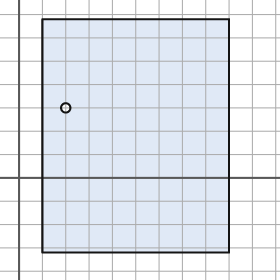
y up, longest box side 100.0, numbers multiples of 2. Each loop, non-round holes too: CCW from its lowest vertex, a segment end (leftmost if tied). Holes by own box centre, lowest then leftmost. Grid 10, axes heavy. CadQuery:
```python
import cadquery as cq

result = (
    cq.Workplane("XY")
    .moveTo(10.0, -32.0)
    .lineTo(90.0, -32.0)
    .lineTo(90.0, 68.0)
    .lineTo(10.0, 68.0)
    .close()
    .moveTo(20.0, 30.0)
    .circle(2.0)
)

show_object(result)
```